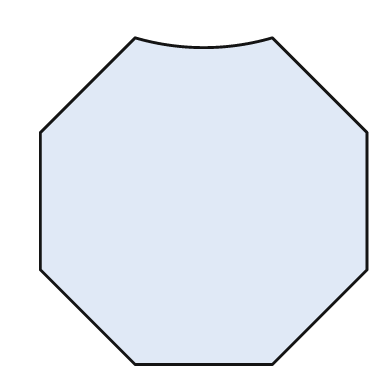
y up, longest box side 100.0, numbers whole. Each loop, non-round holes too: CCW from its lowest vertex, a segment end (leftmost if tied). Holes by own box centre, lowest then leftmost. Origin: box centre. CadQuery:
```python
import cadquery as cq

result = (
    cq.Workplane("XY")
    .moveTo(-21.0, -50.0)
    .lineTo(21.0, -50.0)
    .lineTo(50.0, -21.0)
    .lineTo(50.0, 21.0)
    .lineTo(21.0, 50.0)
    .threePointArc((0.0, 47.0), (-21.0, 50.0))
    .lineTo(-50.0, 21.0)
    .lineTo(-50.0, -21.0)
    .close()
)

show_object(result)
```